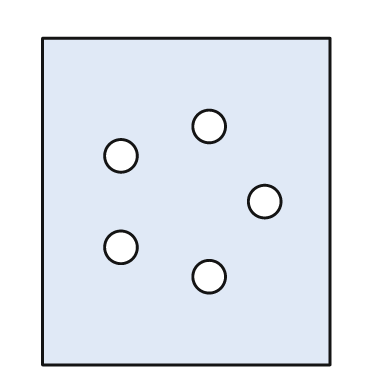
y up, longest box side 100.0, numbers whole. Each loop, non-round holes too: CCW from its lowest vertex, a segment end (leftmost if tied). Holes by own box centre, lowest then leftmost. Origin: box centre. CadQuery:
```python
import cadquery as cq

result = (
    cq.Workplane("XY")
    .moveTo(-44.0, -50.0)
    .lineTo(44.0, -50.0)
    .lineTo(44.0, 50.0)
    .lineTo(-44.0, 50.0)
    .close()
    .moveTo(7.0, -23.0)
    .circle(5.0)
    .moveTo(-20.0, -14.0)
    .circle(5.0)
    .moveTo(24.0, 0.0)
    .circle(5.0)
    .moveTo(-20.0, 14.0)
    .circle(5.0)
    .moveTo(7.0, 23.0)
    .circle(5.0)
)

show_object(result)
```